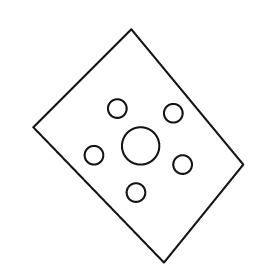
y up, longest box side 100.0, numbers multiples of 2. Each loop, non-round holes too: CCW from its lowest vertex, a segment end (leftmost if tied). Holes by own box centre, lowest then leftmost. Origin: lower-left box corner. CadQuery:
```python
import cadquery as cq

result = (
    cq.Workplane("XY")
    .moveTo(56.0, 0.0)
    .lineTo(90.0, 42.0)
    .lineTo(42.0, 100.0)
    .lineTo(0.0, 58.0)
    .close()
    .moveTo(44.0, 30.0)
    .circle(4.0)
    .moveTo(64.0, 42.0)
    .circle(4.0)
    .moveTo(26.0, 46.0)
    .circle(4.0)
    .moveTo(46.0, 50.0)
    .circle(8.0)
    .moveTo(60.0, 64.0)
    .circle(4.0)
    .moveTo(36.0, 66.0)
    .circle(4.0)
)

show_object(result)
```